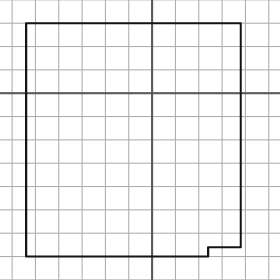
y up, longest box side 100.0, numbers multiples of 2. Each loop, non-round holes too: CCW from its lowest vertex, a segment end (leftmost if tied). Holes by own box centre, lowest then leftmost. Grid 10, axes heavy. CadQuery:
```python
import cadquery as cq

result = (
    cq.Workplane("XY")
    .moveTo(-54.0, -70.0)
    .lineTo(24.0, -70.0)
    .lineTo(24.0, -66.0)
    .lineTo(38.0, -66.0)
    .lineTo(38.0, 30.0)
    .lineTo(-54.0, 30.0)
    .close()
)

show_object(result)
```